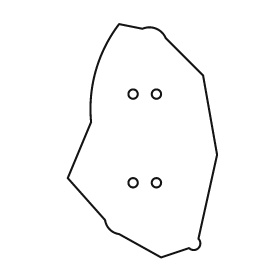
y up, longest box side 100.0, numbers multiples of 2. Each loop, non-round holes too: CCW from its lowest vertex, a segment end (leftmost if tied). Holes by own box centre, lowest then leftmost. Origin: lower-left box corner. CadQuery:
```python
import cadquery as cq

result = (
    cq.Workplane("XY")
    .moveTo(40.0, 0.0)
    .lineTo(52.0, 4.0)
    .threePointArc((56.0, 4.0), (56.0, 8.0))
    .lineTo(64.0, 44.0)
    .lineTo(58.0, 78.0)
    .lineTo(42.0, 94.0)
    .threePointArc((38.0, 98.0), (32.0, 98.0))
    .lineTo(22.0, 100.0)
    .threePointArc((12.0, 80.0), (10.0, 58.0))
    .lineTo(0.0, 34.0)
    .lineTo(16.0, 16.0)
    .threePointArc((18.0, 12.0), (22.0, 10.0))
    .close()
    .moveTo(28.0, 32.0)
    .circle(2.0)
    .moveTo(38.0, 32.0)
    .circle(2.0)
    .moveTo(28.0, 70.0)
    .circle(2.0)
    .moveTo(38.0, 70.0)
    .circle(2.0)
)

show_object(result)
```